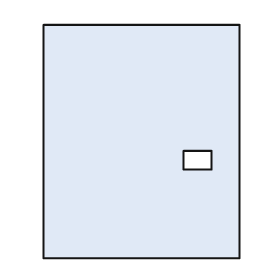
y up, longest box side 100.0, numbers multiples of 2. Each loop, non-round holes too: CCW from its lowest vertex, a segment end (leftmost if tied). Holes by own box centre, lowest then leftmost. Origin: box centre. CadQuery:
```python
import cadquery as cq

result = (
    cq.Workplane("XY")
    .moveTo(-42.0, -50.0)
    .lineTo(42.0, -50.0)
    .lineTo(42.0, 50.0)
    .lineTo(-42.0, 50.0)
    .close()
    .moveTo(18.0, -12.0)
    .lineTo(30.0, -12.0)
    .lineTo(30.0, -4.0)
    .lineTo(18.0, -4.0)
    .close()
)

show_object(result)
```